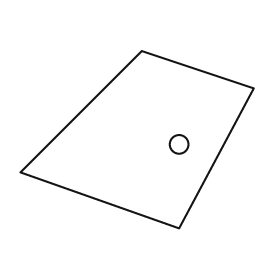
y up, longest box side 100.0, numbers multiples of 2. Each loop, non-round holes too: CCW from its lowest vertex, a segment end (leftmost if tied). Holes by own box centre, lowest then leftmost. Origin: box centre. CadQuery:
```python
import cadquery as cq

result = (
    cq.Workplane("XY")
    .moveTo(18.0, -38.0)
    .lineTo(50.0, 22.0)
    .lineTo(2.0, 38.0)
    .lineTo(-50.0, -14.0)
    .close()
    .moveTo(18.0, -2.0)
    .circle(4.0)
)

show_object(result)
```